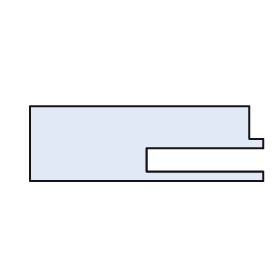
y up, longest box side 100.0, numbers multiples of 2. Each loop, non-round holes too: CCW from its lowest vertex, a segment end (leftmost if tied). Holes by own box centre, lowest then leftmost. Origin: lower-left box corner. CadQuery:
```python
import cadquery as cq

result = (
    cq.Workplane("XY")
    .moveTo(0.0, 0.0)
    .lineTo(100.0, 0.0)
    .lineTo(100.0, 4.0)
    .lineTo(50.0, 4.0)
    .lineTo(50.0, 14.0)
    .lineTo(100.0, 14.0)
    .lineTo(100.0, 18.0)
    .lineTo(94.0, 18.0)
    .lineTo(94.0, 32.0)
    .lineTo(0.0, 32.0)
    .close()
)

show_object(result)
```